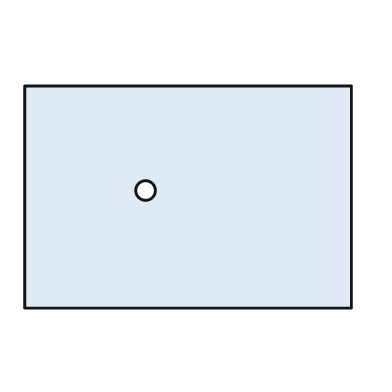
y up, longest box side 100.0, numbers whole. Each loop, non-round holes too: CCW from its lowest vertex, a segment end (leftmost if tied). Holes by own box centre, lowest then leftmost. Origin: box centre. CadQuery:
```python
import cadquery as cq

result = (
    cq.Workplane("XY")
    .moveTo(-50.0, -34.0)
    .lineTo(50.0, -34.0)
    .lineTo(50.0, 34.0)
    .lineTo(-50.0, 34.0)
    .close()
    .moveTo(-13.0, 2.0)
    .circle(3.0)
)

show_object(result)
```